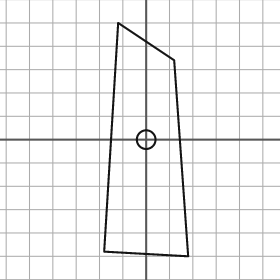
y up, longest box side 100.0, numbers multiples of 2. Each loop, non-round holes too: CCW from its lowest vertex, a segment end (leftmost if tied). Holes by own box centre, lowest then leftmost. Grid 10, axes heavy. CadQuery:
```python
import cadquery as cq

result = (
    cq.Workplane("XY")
    .moveTo(18.0, -50.0)
    .lineTo(12.0, 34.0)
    .lineTo(-12.0, 50.0)
    .lineTo(-18.0, -48.0)
    .close()
    .moveTo(0.0, 0.0)
    .circle(4.0)
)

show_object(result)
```